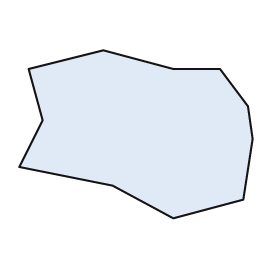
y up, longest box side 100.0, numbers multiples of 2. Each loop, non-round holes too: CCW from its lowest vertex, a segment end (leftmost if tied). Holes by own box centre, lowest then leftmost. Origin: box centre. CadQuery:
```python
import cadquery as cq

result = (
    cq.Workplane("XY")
    .moveTo(16.0, -36.0)
    .lineTo(46.0, -28.0)
    .lineTo(50.0, -2.0)
    .lineTo(48.0, 12.0)
    .lineTo(36.0, 28.0)
    .lineTo(16.0, 28.0)
    .lineTo(-14.0, 36.0)
    .lineTo(-46.0, 28.0)
    .lineTo(-40.0, 6.0)
    .lineTo(-50.0, -14.0)
    .lineTo(-10.0, -22.0)
    .close()
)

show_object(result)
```